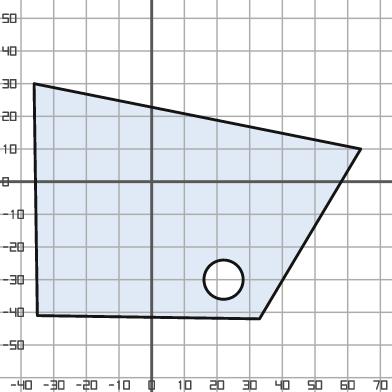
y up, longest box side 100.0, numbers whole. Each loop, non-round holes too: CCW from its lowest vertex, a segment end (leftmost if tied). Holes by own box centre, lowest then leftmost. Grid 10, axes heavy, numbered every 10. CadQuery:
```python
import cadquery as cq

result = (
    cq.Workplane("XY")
    .moveTo(33.0, -42.0)
    .lineTo(64.0, 10.0)
    .lineTo(-36.0, 30.0)
    .lineTo(-35.0, -41.0)
    .close()
    .moveTo(22.0, -30.0)
    .circle(6.0)
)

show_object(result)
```